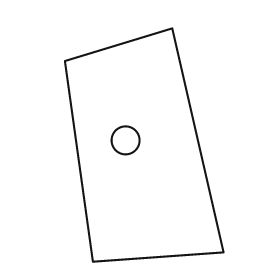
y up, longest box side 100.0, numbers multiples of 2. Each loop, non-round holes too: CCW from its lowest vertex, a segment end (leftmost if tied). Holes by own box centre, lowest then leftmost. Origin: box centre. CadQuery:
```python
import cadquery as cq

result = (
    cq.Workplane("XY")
    .moveTo(-22.0, -50.0)
    .lineTo(34.0, -46.0)
    .lineTo(12.0, 50.0)
    .lineTo(-34.0, 36.0)
    .close()
    .moveTo(-8.0, 2.0)
    .circle(6.0)
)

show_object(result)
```